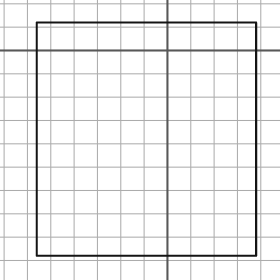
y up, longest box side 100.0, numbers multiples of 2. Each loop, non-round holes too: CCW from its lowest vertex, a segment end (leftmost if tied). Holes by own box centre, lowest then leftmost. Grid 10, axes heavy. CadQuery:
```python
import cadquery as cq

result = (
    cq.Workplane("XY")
    .moveTo(-56.0, -88.0)
    .lineTo(38.0, -88.0)
    .lineTo(38.0, 12.0)
    .lineTo(-56.0, 12.0)
    .close()
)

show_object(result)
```